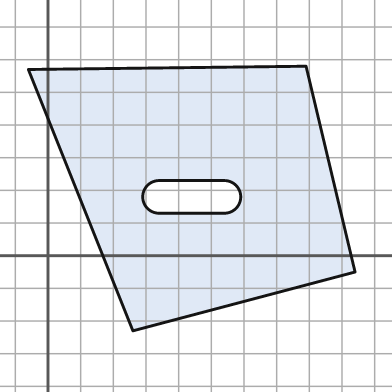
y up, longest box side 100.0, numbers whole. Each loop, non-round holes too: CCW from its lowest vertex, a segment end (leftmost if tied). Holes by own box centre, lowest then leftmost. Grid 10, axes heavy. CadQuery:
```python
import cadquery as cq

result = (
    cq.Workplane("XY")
    .moveTo(26.0, -23.0)
    .lineTo(94.0, -5.0)
    .lineTo(79.0, 58.0)
    .lineTo(-6.0, 57.0)
    .close()
    .moveTo(34.0, 13.0)
    .lineTo(54.0, 13.0)
    .threePointArc((59.0, 18.0), (54.0, 23.0))
    .lineTo(34.0, 23.0)
    .threePointArc((29.0, 18.0), (34.0, 13.0))
    .close()
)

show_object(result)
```